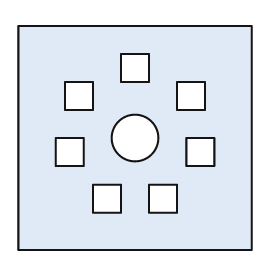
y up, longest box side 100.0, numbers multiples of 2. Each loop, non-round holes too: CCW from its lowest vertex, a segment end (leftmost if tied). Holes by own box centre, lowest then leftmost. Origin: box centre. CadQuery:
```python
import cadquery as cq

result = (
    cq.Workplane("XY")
    .moveTo(-50.0, -48.0)
    .lineTo(50.0, -48.0)
    .lineTo(50.0, 48.0)
    .lineTo(-50.0, 48.0)
    .close()
    .moveTo(-18.0, -32.0)
    .lineTo(-6.0, -32.0)
    .lineTo(-6.0, -20.0)
    .lineTo(-18.0, -20.0)
    .close()
    .moveTo(6.0, -32.0)
    .lineTo(18.0, -32.0)
    .lineTo(18.0, -20.0)
    .lineTo(6.0, -20.0)
    .close()
    .moveTo(-34.0, -12.0)
    .lineTo(-22.0, -12.0)
    .lineTo(-22.0, 0.0)
    .lineTo(-34.0, 0.0)
    .close()
    .moveTo(22.0, -12.0)
    .lineTo(34.0, -12.0)
    .lineTo(34.0, 0.0)
    .lineTo(22.0, 0.0)
    .close()
    .moveTo(0.0, 0.0)
    .circle(10.0)
    .moveTo(-30.0, 12.0)
    .lineTo(-18.0, 12.0)
    .lineTo(-18.0, 24.0)
    .lineTo(-30.0, 24.0)
    .close()
    .moveTo(18.0, 12.0)
    .lineTo(30.0, 12.0)
    .lineTo(30.0, 24.0)
    .lineTo(18.0, 24.0)
    .close()
    .moveTo(-6.0, 24.0)
    .lineTo(6.0, 24.0)
    .lineTo(6.0, 36.0)
    .lineTo(-6.0, 36.0)
    .close()
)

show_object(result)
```